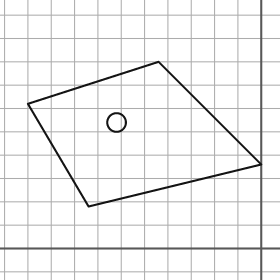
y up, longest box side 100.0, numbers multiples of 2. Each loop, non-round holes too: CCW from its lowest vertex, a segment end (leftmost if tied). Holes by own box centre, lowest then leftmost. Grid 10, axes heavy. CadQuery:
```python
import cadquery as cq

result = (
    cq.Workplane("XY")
    .moveTo(-74.0, 18.0)
    .lineTo(0.0, 36.0)
    .lineTo(-44.0, 80.0)
    .lineTo(-100.0, 62.0)
    .close()
    .moveTo(-62.0, 54.0)
    .circle(4.0)
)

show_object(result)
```